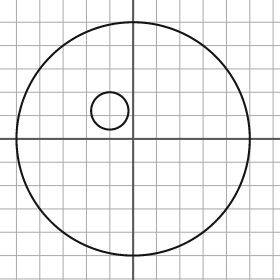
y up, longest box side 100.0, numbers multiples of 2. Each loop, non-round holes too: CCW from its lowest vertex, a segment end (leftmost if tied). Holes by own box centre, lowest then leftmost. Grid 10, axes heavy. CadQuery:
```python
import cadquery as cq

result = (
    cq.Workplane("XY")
    .moveTo(0.0, 0.0)
    .circle(50.0)
    .moveTo(-10.0, 12.0)
    .circle(8.0)
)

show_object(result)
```